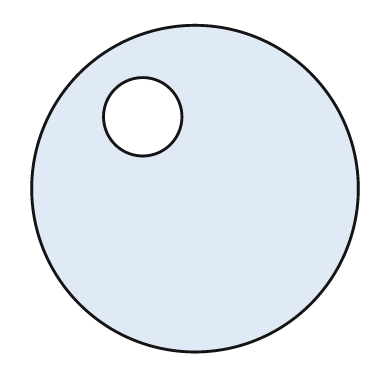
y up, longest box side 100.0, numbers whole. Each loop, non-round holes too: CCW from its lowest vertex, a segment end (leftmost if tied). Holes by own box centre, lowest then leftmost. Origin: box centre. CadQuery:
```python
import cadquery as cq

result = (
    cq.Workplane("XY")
    .moveTo(0.0, 0.0)
    .circle(50.0)
    .moveTo(-16.0, 22.0)
    .circle(12.0)
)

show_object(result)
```